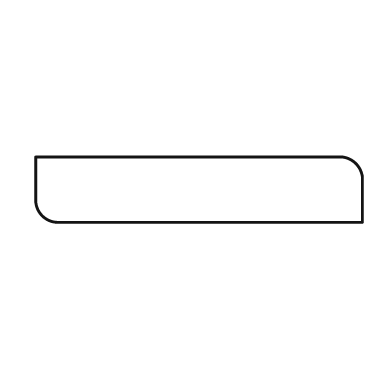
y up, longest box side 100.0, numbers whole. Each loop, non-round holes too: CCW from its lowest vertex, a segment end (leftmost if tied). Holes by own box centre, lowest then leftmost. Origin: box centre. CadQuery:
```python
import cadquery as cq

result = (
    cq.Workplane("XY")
    .moveTo(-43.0, -10.0)
    .lineTo(50.0, -10.0)
    .lineTo(50.0, 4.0)
    .threePointArc((48.0, 8.0), (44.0, 10.0))
    .lineTo(-50.0, 10.0)
    .lineTo(-50.0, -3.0)
    .threePointArc((-48.0, -8.0), (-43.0, -10.0))
    .close()
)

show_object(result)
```